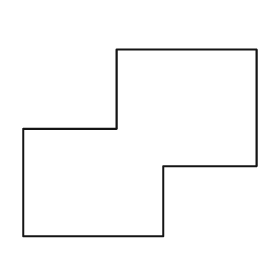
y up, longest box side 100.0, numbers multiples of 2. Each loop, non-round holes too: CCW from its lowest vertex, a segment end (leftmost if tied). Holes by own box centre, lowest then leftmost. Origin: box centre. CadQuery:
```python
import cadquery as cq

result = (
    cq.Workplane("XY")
    .moveTo(-50.0, -40.0)
    .lineTo(10.0, -40.0)
    .lineTo(10.0, -10.0)
    .lineTo(50.0, -10.0)
    .lineTo(50.0, 40.0)
    .lineTo(-10.0, 40.0)
    .lineTo(-10.0, 6.0)
    .lineTo(-50.0, 6.0)
    .close()
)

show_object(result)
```